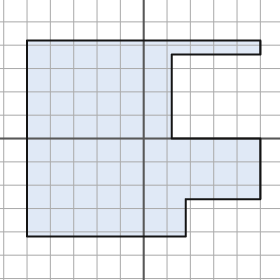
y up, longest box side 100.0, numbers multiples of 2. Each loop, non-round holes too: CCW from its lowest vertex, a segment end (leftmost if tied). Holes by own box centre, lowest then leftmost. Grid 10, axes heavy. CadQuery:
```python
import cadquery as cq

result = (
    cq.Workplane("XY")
    .moveTo(-50.0, -42.0)
    .lineTo(18.0, -42.0)
    .lineTo(18.0, -26.0)
    .lineTo(50.0, -26.0)
    .lineTo(50.0, 0.0)
    .lineTo(12.0, 0.0)
    .lineTo(12.0, 36.0)
    .lineTo(50.0, 36.0)
    .lineTo(50.0, 42.0)
    .lineTo(-50.0, 42.0)
    .close()
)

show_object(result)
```